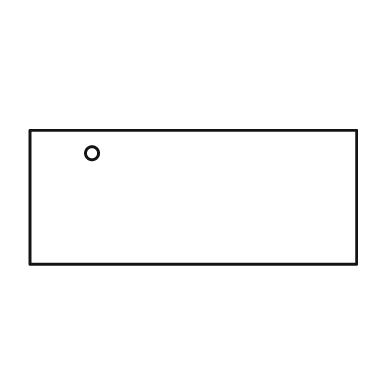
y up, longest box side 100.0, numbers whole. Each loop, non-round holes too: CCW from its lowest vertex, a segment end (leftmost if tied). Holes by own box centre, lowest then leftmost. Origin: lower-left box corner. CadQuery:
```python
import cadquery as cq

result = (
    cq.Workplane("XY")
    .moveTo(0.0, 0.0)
    .lineTo(100.0, 0.0)
    .lineTo(100.0, 41.0)
    .lineTo(0.0, 41.0)
    .close()
    .moveTo(19.0, 34.0)
    .circle(2.0)
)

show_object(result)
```